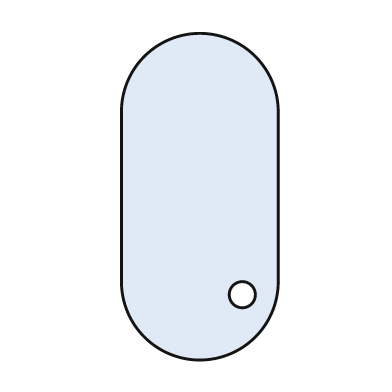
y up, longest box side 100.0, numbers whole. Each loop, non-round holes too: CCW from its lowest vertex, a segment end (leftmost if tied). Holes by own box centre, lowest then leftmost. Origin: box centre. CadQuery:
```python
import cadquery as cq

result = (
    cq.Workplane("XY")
    .moveTo(-24.0, -26.0)
    .threePointArc((0.0, -50.0), (24.0, -26.0))
    .lineTo(24.0, 26.0)
    .threePointArc((0.0, 50.0), (-24.0, 26.0))
    .close()
    .moveTo(13.0, -30.0)
    .circle(4.0)
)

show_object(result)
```